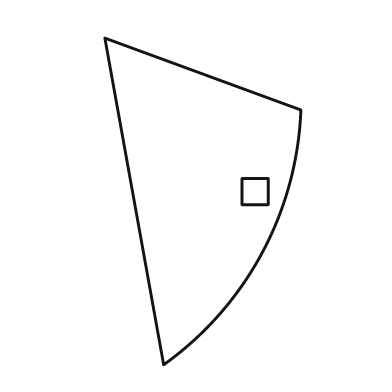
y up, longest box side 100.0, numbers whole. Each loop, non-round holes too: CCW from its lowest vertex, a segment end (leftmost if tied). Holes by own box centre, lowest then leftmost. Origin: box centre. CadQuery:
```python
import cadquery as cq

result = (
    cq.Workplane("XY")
    .moveTo(-12.0, -50.0)
    .threePointArc((18.0, -16.0), (30.0, 28.0))
    .lineTo(-30.0, 50.0)
    .close()
    .moveTo(12.0, -1.0)
    .lineTo(20.0, -1.0)
    .lineTo(20.0, 7.0)
    .lineTo(12.0, 7.0)
    .close()
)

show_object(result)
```